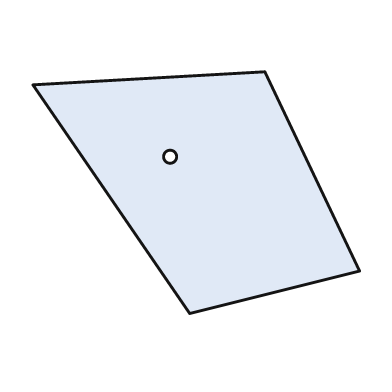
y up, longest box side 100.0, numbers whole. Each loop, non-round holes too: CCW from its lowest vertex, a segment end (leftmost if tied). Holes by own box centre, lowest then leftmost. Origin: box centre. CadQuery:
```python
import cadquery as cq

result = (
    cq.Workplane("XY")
    .moveTo(-2.0, -37.0)
    .lineTo(50.0, -24.0)
    .lineTo(21.0, 37.0)
    .lineTo(-50.0, 33.0)
    .close()
    .moveTo(-8.0, 11.0)
    .circle(2.0)
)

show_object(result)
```